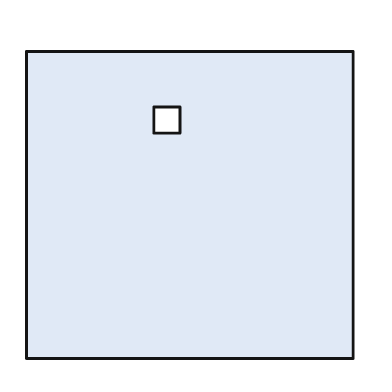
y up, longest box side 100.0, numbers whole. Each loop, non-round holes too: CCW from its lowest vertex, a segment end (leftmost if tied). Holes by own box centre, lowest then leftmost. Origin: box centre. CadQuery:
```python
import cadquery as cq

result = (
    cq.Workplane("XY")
    .moveTo(-50.0, -47.0)
    .lineTo(50.0, -47.0)
    .lineTo(50.0, 47.0)
    .lineTo(-50.0, 47.0)
    .close()
    .moveTo(-11.0, 22.0)
    .lineTo(-3.0, 22.0)
    .lineTo(-3.0, 30.0)
    .lineTo(-11.0, 30.0)
    .close()
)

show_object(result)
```